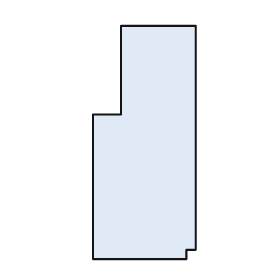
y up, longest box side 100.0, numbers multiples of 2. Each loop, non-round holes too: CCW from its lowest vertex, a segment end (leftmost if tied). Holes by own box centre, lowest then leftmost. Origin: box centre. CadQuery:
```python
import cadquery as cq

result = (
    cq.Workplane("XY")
    .moveTo(-22.0, -50.0)
    .lineTo(18.0, -50.0)
    .lineTo(18.0, -46.0)
    .lineTo(22.0, -46.0)
    .lineTo(22.0, 50.0)
    .lineTo(-10.0, 50.0)
    .lineTo(-10.0, 12.0)
    .lineTo(-22.0, 12.0)
    .close()
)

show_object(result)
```